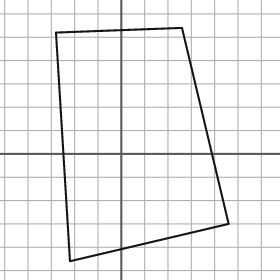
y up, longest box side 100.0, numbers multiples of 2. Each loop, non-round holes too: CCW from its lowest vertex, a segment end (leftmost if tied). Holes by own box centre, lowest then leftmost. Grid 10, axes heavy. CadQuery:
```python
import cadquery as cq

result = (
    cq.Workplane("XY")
    .moveTo(-22.0, -46.0)
    .lineTo(46.0, -30.0)
    .lineTo(26.0, 54.0)
    .lineTo(-28.0, 52.0)
    .close()
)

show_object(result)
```